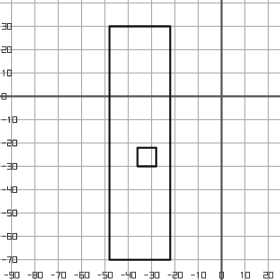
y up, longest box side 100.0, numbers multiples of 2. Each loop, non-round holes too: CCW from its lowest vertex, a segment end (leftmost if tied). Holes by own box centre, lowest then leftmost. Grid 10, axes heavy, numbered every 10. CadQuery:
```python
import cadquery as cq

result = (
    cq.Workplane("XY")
    .moveTo(-48.0, -70.0)
    .lineTo(-22.0, -70.0)
    .lineTo(-22.0, 30.0)
    .lineTo(-48.0, 30.0)
    .close()
    .moveTo(-36.0, -30.0)
    .lineTo(-28.0, -30.0)
    .lineTo(-28.0, -22.0)
    .lineTo(-36.0, -22.0)
    .close()
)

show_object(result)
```